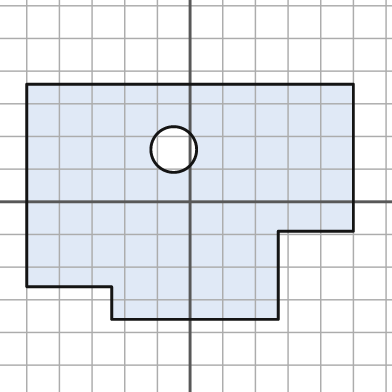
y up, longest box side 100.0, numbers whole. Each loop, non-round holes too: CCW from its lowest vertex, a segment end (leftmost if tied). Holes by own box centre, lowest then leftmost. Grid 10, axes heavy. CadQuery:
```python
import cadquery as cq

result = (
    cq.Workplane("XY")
    .moveTo(-24.0, -36.0)
    .lineTo(27.0, -36.0)
    .lineTo(27.0, -9.0)
    .lineTo(50.0, -9.0)
    .lineTo(50.0, 36.0)
    .lineTo(-50.0, 36.0)
    .lineTo(-50.0, -26.0)
    .lineTo(-24.0, -26.0)
    .close()
    .moveTo(-5.0, 16.0)
    .circle(7.0)
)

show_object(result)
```